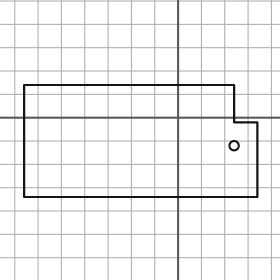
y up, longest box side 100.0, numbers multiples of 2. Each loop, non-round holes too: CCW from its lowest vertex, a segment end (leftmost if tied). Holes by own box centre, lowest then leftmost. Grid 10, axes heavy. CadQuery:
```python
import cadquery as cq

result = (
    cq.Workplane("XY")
    .moveTo(-66.0, -34.0)
    .lineTo(34.0, -34.0)
    .lineTo(34.0, -2.0)
    .lineTo(24.0, -2.0)
    .lineTo(24.0, 14.0)
    .lineTo(-66.0, 14.0)
    .close()
    .moveTo(24.0, -12.0)
    .circle(2.0)
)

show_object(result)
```